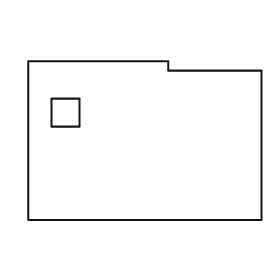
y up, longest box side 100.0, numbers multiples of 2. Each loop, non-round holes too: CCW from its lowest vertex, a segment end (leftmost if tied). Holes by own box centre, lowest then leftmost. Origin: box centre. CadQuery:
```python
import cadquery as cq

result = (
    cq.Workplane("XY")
    .moveTo(-50.0, -34.0)
    .lineTo(50.0, -34.0)
    .lineTo(50.0, 30.0)
    .lineTo(10.0, 30.0)
    .lineTo(10.0, 34.0)
    .lineTo(-50.0, 34.0)
    .close()
    .moveTo(-40.0, 6.0)
    .lineTo(-28.0, 6.0)
    .lineTo(-28.0, 18.0)
    .lineTo(-40.0, 18.0)
    .close()
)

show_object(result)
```